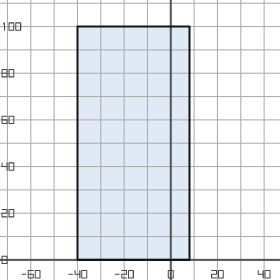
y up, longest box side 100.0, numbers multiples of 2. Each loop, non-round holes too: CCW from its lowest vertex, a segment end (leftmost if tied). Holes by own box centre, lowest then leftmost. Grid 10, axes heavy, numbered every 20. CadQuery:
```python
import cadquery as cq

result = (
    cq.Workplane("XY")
    .moveTo(-40.0, 0.0)
    .lineTo(8.0, 0.0)
    .lineTo(8.0, 100.0)
    .lineTo(-40.0, 100.0)
    .close()
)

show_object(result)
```